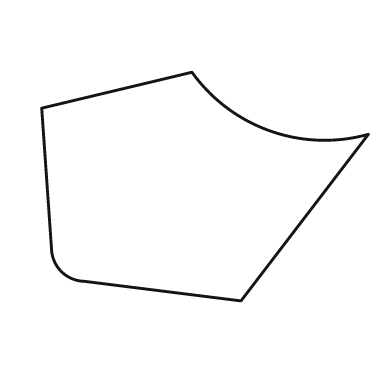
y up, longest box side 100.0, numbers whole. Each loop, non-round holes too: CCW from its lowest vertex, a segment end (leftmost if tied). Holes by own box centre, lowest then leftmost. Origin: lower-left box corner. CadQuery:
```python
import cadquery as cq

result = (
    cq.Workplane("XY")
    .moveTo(61.0, 0.0)
    .lineTo(100.0, 51.0)
    .threePointArc((70.0, 52.0), (46.0, 70.0))
    .lineTo(0.0, 59.0)
    .lineTo(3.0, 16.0)
    .threePointArc((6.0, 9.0), (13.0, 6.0))
    .close()
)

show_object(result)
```